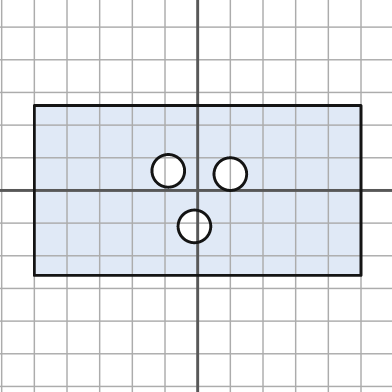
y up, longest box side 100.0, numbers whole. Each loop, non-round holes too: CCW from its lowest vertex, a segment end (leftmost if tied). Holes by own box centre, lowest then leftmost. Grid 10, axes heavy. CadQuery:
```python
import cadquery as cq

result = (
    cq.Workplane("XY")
    .moveTo(-50.0, -26.0)
    .lineTo(50.0, -26.0)
    .lineTo(50.0, 26.0)
    .lineTo(-50.0, 26.0)
    .close()
    .moveTo(-1.0, -11.0)
    .circle(5.0)
    .moveTo(10.0, 5.0)
    .circle(5.0)
    .moveTo(-9.0, 6.0)
    .circle(5.0)
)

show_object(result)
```